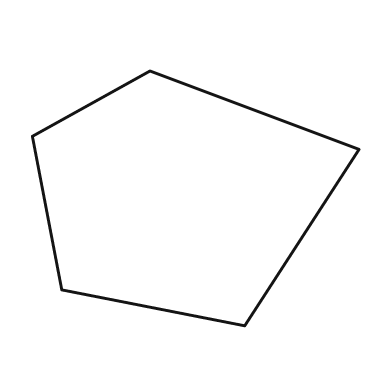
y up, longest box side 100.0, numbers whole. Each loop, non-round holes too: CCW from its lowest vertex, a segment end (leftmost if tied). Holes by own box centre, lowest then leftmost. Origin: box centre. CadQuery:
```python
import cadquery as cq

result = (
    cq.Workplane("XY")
    .moveTo(15.0, -39.0)
    .lineTo(50.0, 15.0)
    .lineTo(-14.0, 39.0)
    .lineTo(-50.0, 19.0)
    .lineTo(-41.0, -28.0)
    .close()
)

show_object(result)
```